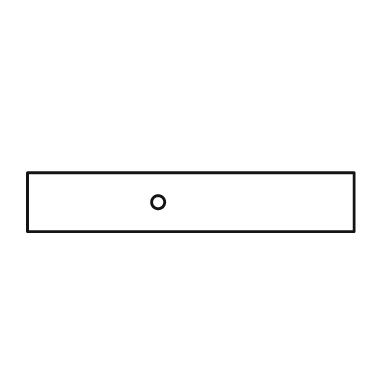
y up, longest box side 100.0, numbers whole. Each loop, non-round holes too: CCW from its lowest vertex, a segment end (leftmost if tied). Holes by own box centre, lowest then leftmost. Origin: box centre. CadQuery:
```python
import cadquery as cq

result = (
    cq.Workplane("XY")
    .moveTo(-50.0, -9.0)
    .lineTo(50.0, -9.0)
    .lineTo(50.0, 9.0)
    .lineTo(-50.0, 9.0)
    .close()
    .moveTo(-10.0, 0.0)
    .circle(2.0)
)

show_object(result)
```